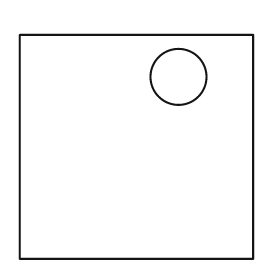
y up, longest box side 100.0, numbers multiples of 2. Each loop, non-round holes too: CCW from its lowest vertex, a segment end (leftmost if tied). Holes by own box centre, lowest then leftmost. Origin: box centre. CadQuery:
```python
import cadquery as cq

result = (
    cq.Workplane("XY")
    .moveTo(-50.0, -48.0)
    .lineTo(50.0, -48.0)
    .lineTo(50.0, 48.0)
    .lineTo(-50.0, 48.0)
    .close()
    .moveTo(18.0, 30.0)
    .circle(12.0)
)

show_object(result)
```